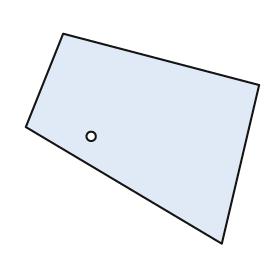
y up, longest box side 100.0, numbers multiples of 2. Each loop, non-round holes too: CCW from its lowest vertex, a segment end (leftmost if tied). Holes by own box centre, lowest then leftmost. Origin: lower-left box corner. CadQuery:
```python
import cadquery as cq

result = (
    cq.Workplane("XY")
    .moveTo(84.0, 0.0)
    .lineTo(100.0, 68.0)
    .lineTo(16.0, 90.0)
    .lineTo(0.0, 50.0)
    .close()
    .moveTo(28.0, 46.0)
    .circle(2.0)
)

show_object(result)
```